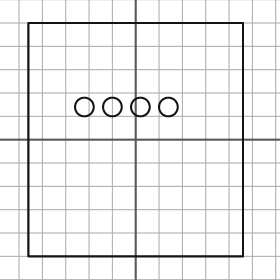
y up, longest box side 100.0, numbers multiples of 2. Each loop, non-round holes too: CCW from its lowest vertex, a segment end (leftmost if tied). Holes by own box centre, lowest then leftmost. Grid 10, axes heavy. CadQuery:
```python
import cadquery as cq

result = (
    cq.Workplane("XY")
    .moveTo(-46.0, -50.0)
    .lineTo(46.0, -50.0)
    .lineTo(46.0, 50.0)
    .lineTo(-46.0, 50.0)
    .close()
    .moveTo(-22.0, 14.0)
    .circle(4.0)
    .moveTo(-10.0, 14.0)
    .circle(4.0)
    .moveTo(2.0, 14.0)
    .circle(4.0)
    .moveTo(14.0, 14.0)
    .circle(4.0)
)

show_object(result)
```